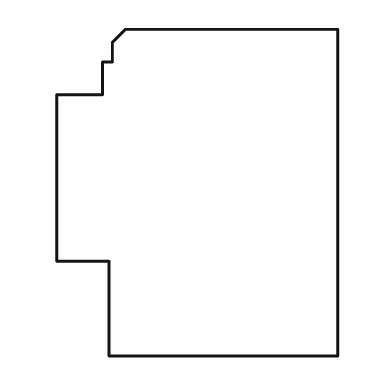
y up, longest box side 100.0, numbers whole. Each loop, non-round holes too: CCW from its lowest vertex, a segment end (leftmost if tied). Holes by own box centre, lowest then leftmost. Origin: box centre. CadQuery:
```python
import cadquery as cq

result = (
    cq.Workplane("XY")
    .moveTo(-27.0, -50.0)
    .lineTo(43.0, -50.0)
    .lineTo(43.0, 50.0)
    .lineTo(-22.0, 50.0)
    .lineTo(-26.0, 46.0)
    .lineTo(-26.0, 40.0)
    .lineTo(-29.0, 40.0)
    .lineTo(-29.0, 30.0)
    .lineTo(-43.0, 30.0)
    .lineTo(-43.0, -21.0)
    .lineTo(-27.0, -21.0)
    .close()
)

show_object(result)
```